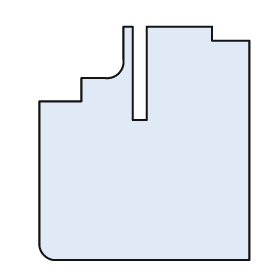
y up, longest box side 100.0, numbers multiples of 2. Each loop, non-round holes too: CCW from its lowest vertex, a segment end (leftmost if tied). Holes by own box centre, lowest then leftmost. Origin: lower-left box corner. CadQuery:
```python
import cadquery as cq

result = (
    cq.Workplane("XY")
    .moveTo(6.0, 0.0)
    .lineTo(90.0, 0.0)
    .lineTo(90.0, 94.0)
    .lineTo(74.0, 94.0)
    .lineTo(74.0, 100.0)
    .lineTo(46.0, 100.0)
    .lineTo(46.0, 60.0)
    .lineTo(40.0, 60.0)
    .lineTo(40.0, 100.0)
    .lineTo(36.0, 100.0)
    .lineTo(36.0, 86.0)
    .threePointArc((34.0, 80.0), (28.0, 78.0))
    .lineTo(18.0, 78.0)
    .lineTo(18.0, 68.0)
    .lineTo(0.0, 68.0)
    .lineTo(0.0, 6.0)
    .threePointArc((2.0, 2.0), (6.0, 0.0))
    .close()
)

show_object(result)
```